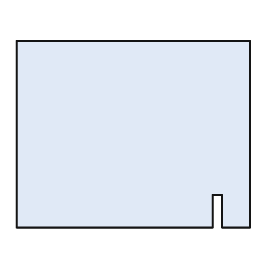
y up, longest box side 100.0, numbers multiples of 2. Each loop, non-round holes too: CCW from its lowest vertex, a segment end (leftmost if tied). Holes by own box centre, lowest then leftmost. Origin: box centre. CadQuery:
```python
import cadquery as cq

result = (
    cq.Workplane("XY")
    .moveTo(-50.0, -40.0)
    .lineTo(34.0, -40.0)
    .lineTo(34.0, -26.0)
    .lineTo(38.0, -26.0)
    .lineTo(38.0, -40.0)
    .lineTo(50.0, -40.0)
    .lineTo(50.0, 40.0)
    .lineTo(-50.0, 40.0)
    .close()
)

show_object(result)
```